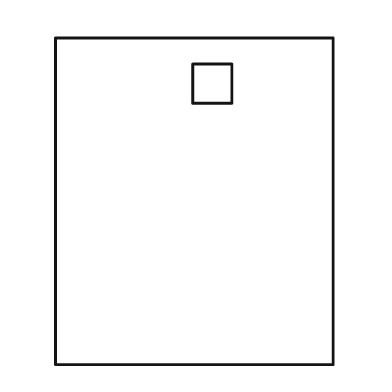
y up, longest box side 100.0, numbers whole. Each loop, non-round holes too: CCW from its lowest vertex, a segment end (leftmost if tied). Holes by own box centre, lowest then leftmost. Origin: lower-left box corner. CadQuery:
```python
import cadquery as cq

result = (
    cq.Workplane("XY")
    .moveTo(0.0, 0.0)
    .lineTo(85.0, 0.0)
    .lineTo(85.0, 100.0)
    .lineTo(0.0, 100.0)
    .close()
    .moveTo(42.0, 80.0)
    .lineTo(54.0, 80.0)
    .lineTo(54.0, 92.0)
    .lineTo(42.0, 92.0)
    .close()
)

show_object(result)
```